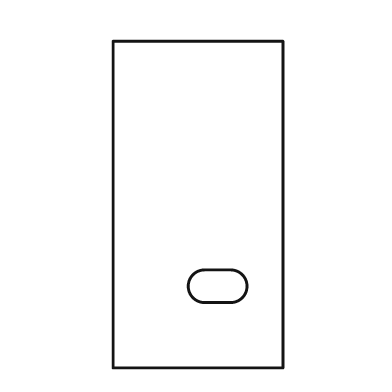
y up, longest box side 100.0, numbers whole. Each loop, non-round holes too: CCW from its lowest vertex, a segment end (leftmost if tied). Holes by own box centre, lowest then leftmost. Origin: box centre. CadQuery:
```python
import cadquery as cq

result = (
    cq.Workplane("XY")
    .moveTo(-26.0, -50.0)
    .lineTo(26.0, -50.0)
    .lineTo(26.0, 50.0)
    .lineTo(-26.0, 50.0)
    .close()
    .moveTo(2.0, -30.0)
    .lineTo(10.0, -30.0)
    .threePointArc((15.0, -25.0), (10.0, -20.0))
    .lineTo(2.0, -20.0)
    .threePointArc((-3.0, -25.0), (2.0, -30.0))
    .close()
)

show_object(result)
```